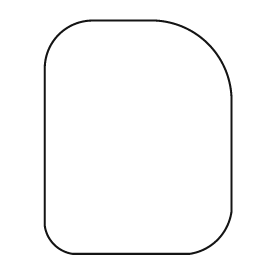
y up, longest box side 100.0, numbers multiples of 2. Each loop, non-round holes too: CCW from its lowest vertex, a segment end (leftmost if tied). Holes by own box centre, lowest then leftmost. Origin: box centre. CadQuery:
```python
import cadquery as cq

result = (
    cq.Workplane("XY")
    .moveTo(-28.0, -50.0)
    .lineTo(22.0, -50.0)
    .threePointArc((34.0, -44.0), (40.0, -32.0))
    .lineTo(40.0, 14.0)
    .threePointArc((30.0, 40.0), (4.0, 50.0))
    .lineTo(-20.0, 50.0)
    .threePointArc((-34.0, 44.0), (-40.0, 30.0))
    .lineTo(-40.0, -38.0)
    .threePointArc((-36.0, -46.0), (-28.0, -50.0))
    .close()
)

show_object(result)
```